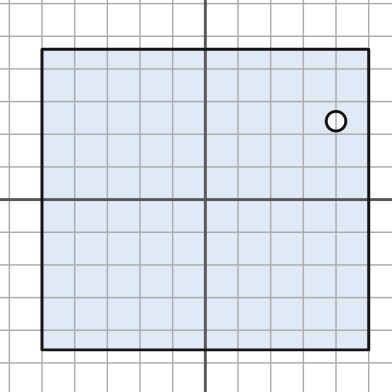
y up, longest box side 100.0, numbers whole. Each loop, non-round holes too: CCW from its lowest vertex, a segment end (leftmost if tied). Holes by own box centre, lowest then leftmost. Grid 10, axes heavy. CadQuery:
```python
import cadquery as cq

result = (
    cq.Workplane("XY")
    .moveTo(-50.0, -46.0)
    .lineTo(50.0, -46.0)
    .lineTo(50.0, 46.0)
    .lineTo(-50.0, 46.0)
    .close()
    .moveTo(40.0, 24.0)
    .circle(3.0)
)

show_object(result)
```